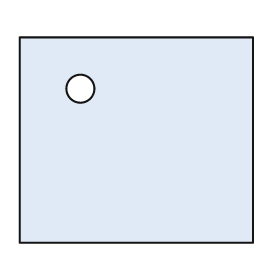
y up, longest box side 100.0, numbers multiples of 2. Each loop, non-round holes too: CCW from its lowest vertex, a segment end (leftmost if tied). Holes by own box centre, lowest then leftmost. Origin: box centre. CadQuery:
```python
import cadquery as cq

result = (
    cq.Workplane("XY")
    .moveTo(-50.0, -44.0)
    .lineTo(50.0, -44.0)
    .lineTo(50.0, 44.0)
    .lineTo(-50.0, 44.0)
    .close()
    .moveTo(-24.0, 22.0)
    .circle(6.0)
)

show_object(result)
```